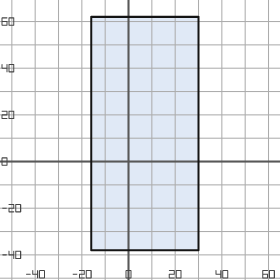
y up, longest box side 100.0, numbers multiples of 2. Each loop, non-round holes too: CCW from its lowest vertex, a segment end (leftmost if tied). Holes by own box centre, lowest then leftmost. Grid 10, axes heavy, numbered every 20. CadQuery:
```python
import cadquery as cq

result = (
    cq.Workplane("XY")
    .moveTo(-16.0, -38.0)
    .lineTo(30.0, -38.0)
    .lineTo(30.0, 62.0)
    .lineTo(-16.0, 62.0)
    .close()
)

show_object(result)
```